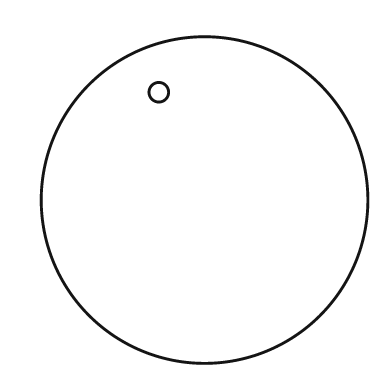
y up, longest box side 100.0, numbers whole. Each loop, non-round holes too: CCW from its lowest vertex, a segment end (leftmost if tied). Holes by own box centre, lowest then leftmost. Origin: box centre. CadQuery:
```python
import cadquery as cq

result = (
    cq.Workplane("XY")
    .moveTo(0.0, 0.0)
    .circle(50.0)
    .moveTo(-14.0, 33.0)
    .circle(3.0)
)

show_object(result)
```